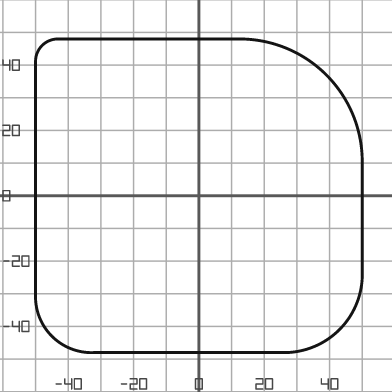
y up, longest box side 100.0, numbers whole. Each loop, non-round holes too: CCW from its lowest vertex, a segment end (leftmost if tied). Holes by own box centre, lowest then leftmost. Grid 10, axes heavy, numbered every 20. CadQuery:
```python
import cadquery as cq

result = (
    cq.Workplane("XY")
    .moveTo(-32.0, -48.0)
    .lineTo(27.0, -48.0)
    .threePointArc((43.0, -41.0), (50.0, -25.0))
    .lineTo(50.0, 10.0)
    .threePointArc((39.0, 37.0), (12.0, 48.0))
    .lineTo(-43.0, 48.0)
    .threePointArc((-48.0, 46.0), (-50.0, 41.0))
    .lineTo(-50.0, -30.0)
    .threePointArc((-45.0, -43.0), (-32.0, -48.0))
    .close()
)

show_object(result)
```